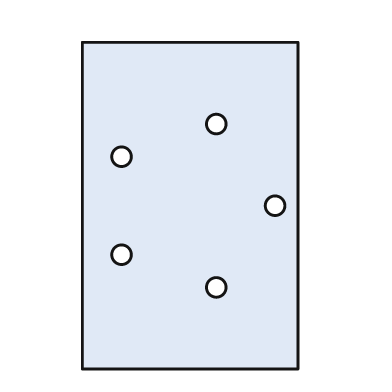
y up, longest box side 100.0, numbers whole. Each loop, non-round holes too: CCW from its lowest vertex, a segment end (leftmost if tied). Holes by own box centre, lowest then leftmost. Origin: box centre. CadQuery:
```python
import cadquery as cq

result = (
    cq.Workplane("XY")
    .moveTo(-33.0, -50.0)
    .lineTo(33.0, -50.0)
    .lineTo(33.0, 50.0)
    .lineTo(-33.0, 50.0)
    .close()
    .moveTo(8.0, -25.0)
    .circle(3.0)
    .moveTo(-21.0, -15.0)
    .circle(3.0)
    .moveTo(26.0, 0.0)
    .circle(3.0)
    .moveTo(-21.0, 15.0)
    .circle(3.0)
    .moveTo(8.0, 25.0)
    .circle(3.0)
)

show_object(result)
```